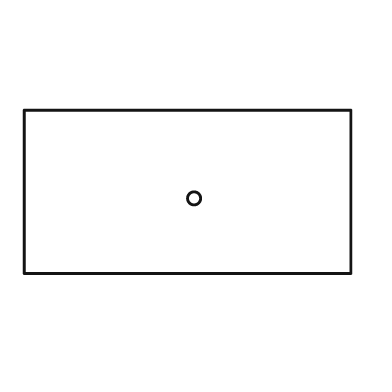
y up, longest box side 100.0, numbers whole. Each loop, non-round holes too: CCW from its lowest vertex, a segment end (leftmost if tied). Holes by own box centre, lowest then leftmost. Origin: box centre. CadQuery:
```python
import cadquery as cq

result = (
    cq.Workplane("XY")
    .moveTo(-50.0, -25.0)
    .lineTo(50.0, -25.0)
    .lineTo(50.0, 25.0)
    .lineTo(-50.0, 25.0)
    .close()
    .moveTo(2.0, -2.0)
    .circle(2.0)
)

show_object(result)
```